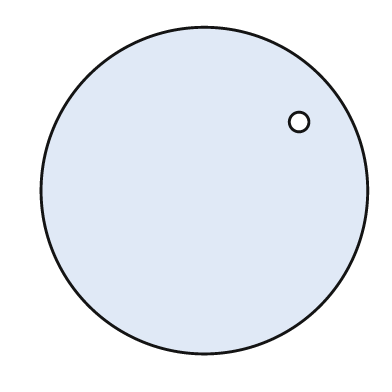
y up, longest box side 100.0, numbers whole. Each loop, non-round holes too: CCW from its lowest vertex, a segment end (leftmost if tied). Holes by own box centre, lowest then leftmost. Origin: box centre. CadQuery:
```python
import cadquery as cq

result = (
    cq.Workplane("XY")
    .moveTo(0.0, 0.0)
    .circle(50.0)
    .moveTo(29.0, 21.0)
    .circle(3.0)
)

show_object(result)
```